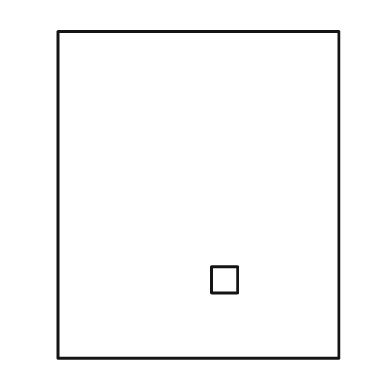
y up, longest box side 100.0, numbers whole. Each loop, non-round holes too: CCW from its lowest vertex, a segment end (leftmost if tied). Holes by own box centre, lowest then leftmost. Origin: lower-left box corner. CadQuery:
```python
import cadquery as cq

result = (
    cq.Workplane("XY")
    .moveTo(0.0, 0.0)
    .lineTo(86.0, 0.0)
    .lineTo(86.0, 100.0)
    .lineTo(0.0, 100.0)
    .close()
    .moveTo(47.0, 20.0)
    .lineTo(55.0, 20.0)
    .lineTo(55.0, 28.0)
    .lineTo(47.0, 28.0)
    .close()
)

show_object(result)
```